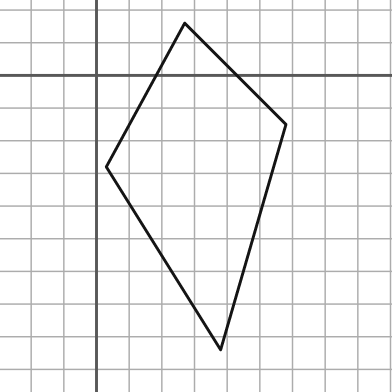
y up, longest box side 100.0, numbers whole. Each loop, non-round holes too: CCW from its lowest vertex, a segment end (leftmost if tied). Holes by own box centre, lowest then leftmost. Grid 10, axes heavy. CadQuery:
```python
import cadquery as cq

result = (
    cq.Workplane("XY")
    .moveTo(38.0, -84.0)
    .lineTo(58.0, -15.0)
    .lineTo(27.0, 16.0)
    .lineTo(3.0, -28.0)
    .close()
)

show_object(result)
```